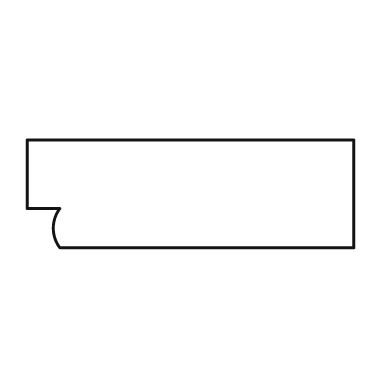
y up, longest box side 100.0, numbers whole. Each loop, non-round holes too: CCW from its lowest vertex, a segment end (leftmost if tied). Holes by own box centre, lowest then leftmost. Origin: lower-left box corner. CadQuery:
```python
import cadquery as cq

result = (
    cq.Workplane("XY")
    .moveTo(10.0, 0.0)
    .lineTo(100.0, 0.0)
    .lineTo(100.0, 33.0)
    .lineTo(0.0, 33.0)
    .lineTo(0.0, 12.0)
    .lineTo(10.0, 12.0)
    .threePointArc((8.0, 6.0), (10.0, 0.0))
    .close()
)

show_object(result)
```